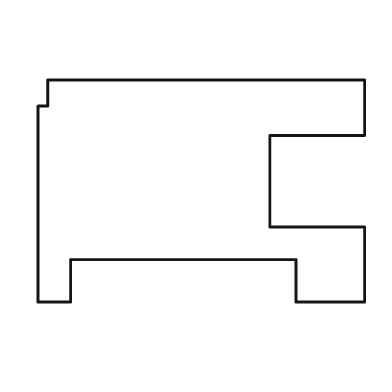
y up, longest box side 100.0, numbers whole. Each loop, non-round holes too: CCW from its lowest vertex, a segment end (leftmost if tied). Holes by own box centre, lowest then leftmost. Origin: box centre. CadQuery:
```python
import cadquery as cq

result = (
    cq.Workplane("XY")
    .moveTo(-50.0, -34.0)
    .lineTo(-40.0, -34.0)
    .lineTo(-40.0, -21.0)
    .lineTo(29.0, -21.0)
    .lineTo(29.0, -34.0)
    .lineTo(50.0, -34.0)
    .lineTo(50.0, -11.0)
    .lineTo(21.0, -11.0)
    .lineTo(21.0, 17.0)
    .lineTo(50.0, 17.0)
    .lineTo(50.0, 34.0)
    .lineTo(-47.0, 34.0)
    .lineTo(-47.0, 26.0)
    .lineTo(-50.0, 26.0)
    .close()
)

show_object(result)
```